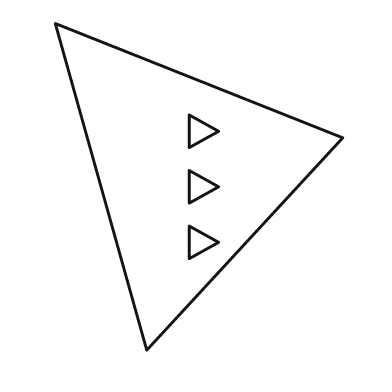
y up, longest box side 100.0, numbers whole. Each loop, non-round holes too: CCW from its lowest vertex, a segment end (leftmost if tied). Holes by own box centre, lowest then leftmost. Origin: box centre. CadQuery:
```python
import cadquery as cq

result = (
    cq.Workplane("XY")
    .moveTo(-16.0, -50.0)
    .lineTo(44.0, 15.0)
    .lineTo(-44.0, 50.0)
    .close()
    .moveTo(-3.0, -22.0)
    .lineTo(6.0, -17.0)
    .lineTo(-3.0, -12.0)
    .close()
    .moveTo(-3.0, -5.0)
    .lineTo(6.0, 0.0)
    .lineTo(-3.0, 5.0)
    .close()
    .moveTo(-3.0, 12.0)
    .lineTo(6.0, 17.0)
    .lineTo(-3.0, 22.0)
    .close()
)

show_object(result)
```